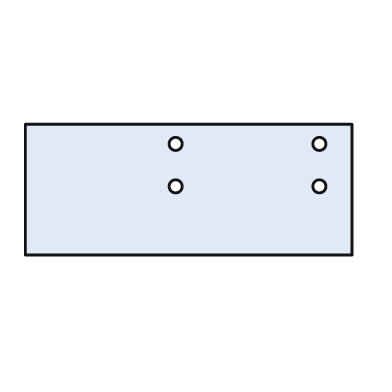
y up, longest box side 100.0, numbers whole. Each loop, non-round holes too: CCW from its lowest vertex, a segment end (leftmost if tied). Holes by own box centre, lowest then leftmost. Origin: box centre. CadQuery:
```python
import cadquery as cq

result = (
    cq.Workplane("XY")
    .moveTo(-50.0, -20.0)
    .lineTo(50.0, -20.0)
    .lineTo(50.0, 20.0)
    .lineTo(-50.0, 20.0)
    .close()
    .moveTo(-4.0, 1.0)
    .circle(2.0)
    .moveTo(40.0, 1.0)
    .circle(2.0)
    .moveTo(-4.0, 14.0)
    .circle(2.0)
    .moveTo(40.0, 14.0)
    .circle(2.0)
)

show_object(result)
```